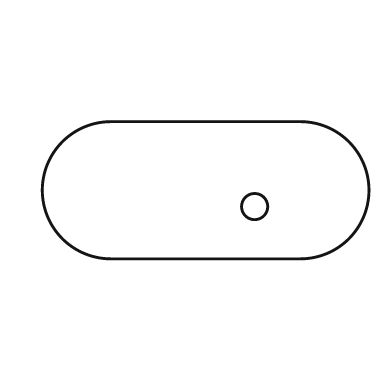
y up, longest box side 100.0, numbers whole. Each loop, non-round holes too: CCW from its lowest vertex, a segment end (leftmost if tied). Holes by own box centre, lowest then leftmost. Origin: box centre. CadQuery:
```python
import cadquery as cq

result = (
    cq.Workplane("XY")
    .moveTo(-29.0, -21.0)
    .lineTo(29.0, -21.0)
    .threePointArc((50.0, 0.0), (29.0, 21.0))
    .lineTo(-29.0, 21.0)
    .threePointArc((-50.0, 0.0), (-29.0, -21.0))
    .close()
    .moveTo(15.0, -5.0)
    .circle(4.0)
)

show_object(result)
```